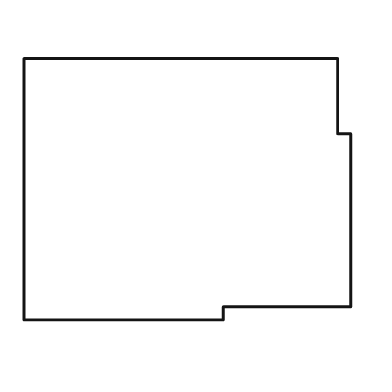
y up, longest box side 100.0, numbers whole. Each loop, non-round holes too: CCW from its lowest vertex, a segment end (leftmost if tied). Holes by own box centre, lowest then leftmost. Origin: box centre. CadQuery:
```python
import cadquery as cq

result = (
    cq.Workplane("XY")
    .moveTo(-50.0, -40.0)
    .lineTo(11.0, -40.0)
    .lineTo(11.0, -36.0)
    .lineTo(50.0, -36.0)
    .lineTo(50.0, 17.0)
    .lineTo(46.0, 17.0)
    .lineTo(46.0, 40.0)
    .lineTo(-50.0, 40.0)
    .close()
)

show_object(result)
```